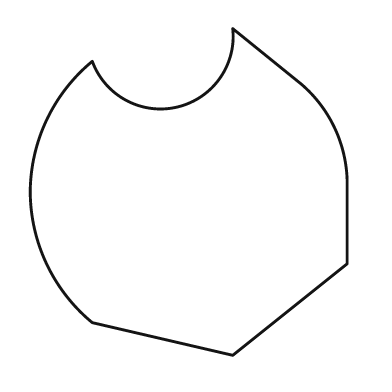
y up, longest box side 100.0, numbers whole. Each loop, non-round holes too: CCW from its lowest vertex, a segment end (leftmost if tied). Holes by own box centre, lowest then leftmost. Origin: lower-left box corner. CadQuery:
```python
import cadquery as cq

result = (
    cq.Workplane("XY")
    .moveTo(62.0, 0.0)
    .lineTo(97.0, 28.0)
    .lineTo(97.0, 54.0)
    .threePointArc((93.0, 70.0), (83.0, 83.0))
    .lineTo(62.0, 100.0)
    .threePointArc((45.0, 76.0), (19.0, 90.0))
    .threePointArc((5.0, 72.0), (0.0, 50.0))
    .threePointArc((5.0, 28.0), (19.0, 10.0))
    .close()
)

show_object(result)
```